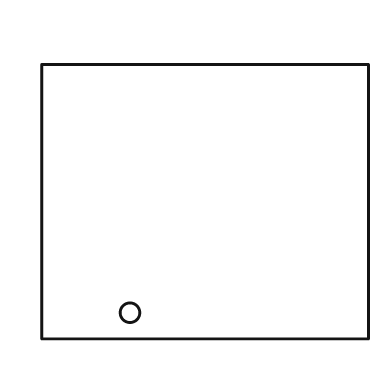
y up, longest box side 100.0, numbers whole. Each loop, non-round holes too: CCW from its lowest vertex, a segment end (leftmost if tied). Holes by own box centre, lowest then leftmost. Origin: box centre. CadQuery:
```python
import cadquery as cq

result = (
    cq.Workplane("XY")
    .moveTo(-50.0, -42.0)
    .lineTo(50.0, -42.0)
    .lineTo(50.0, 42.0)
    .lineTo(-50.0, 42.0)
    .close()
    .moveTo(-23.0, -34.0)
    .circle(3.0)
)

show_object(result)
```